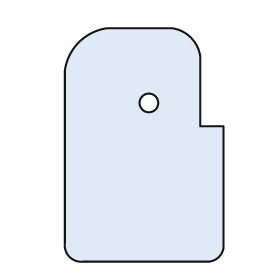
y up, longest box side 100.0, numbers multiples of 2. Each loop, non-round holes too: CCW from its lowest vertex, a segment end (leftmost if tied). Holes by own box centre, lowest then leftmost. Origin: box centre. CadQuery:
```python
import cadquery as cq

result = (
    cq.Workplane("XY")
    .moveTo(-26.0, -50.0)
    .lineTo(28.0, -50.0)
    .threePointArc((32.0, -48.0), (34.0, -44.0))
    .lineTo(34.0, 8.0)
    .lineTo(24.0, 8.0)
    .lineTo(24.0, 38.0)
    .threePointArc((20.0, 46.0), (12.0, 50.0))
    .lineTo(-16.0, 50.0)
    .threePointArc((-28.0, 44.0), (-34.0, 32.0))
    .lineTo(-34.0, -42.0)
    .threePointArc((-32.0, -48.0), (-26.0, -50.0))
    .close()
    .moveTo(2.0, 18.0)
    .circle(4.0)
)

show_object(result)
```